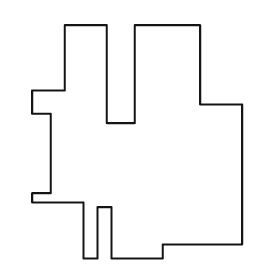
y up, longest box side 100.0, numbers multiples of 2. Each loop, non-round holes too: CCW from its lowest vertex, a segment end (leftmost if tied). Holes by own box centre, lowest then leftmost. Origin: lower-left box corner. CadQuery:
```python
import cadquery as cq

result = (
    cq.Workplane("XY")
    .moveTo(22.0, 0.0)
    .lineTo(28.0, 0.0)
    .lineTo(28.0, 22.0)
    .lineTo(34.0, 22.0)
    .lineTo(34.0, 0.0)
    .lineTo(56.0, 0.0)
    .lineTo(56.0, 6.0)
    .lineTo(90.0, 6.0)
    .lineTo(90.0, 66.0)
    .lineTo(72.0, 66.0)
    .lineTo(72.0, 100.0)
    .lineTo(44.0, 100.0)
    .lineTo(44.0, 58.0)
    .lineTo(32.0, 58.0)
    .lineTo(32.0, 100.0)
    .lineTo(14.0, 100.0)
    .lineTo(14.0, 72.0)
    .lineTo(0.0, 72.0)
    .lineTo(0.0, 62.0)
    .lineTo(8.0, 62.0)
    .lineTo(8.0, 28.0)
    .lineTo(0.0, 28.0)
    .lineTo(0.0, 24.0)
    .lineTo(22.0, 24.0)
    .close()
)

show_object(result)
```